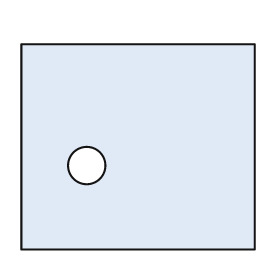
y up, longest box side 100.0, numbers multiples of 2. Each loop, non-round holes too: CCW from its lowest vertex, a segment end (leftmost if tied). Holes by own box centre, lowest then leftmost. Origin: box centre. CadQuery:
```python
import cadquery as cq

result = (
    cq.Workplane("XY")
    .moveTo(-50.0, -44.0)
    .lineTo(50.0, -44.0)
    .lineTo(50.0, 44.0)
    .lineTo(-50.0, 44.0)
    .close()
    .moveTo(-22.0, -8.0)
    .circle(8.0)
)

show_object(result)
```